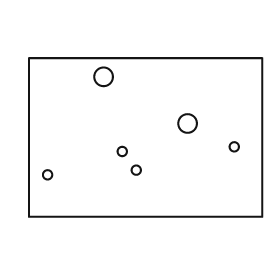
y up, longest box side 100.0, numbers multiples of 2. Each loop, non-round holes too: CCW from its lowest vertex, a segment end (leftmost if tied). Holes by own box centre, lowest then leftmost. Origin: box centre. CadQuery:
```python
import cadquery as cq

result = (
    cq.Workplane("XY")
    .moveTo(-50.0, -34.0)
    .lineTo(50.0, -34.0)
    .lineTo(50.0, 34.0)
    .lineTo(-50.0, 34.0)
    .close()
    .moveTo(-42.0, -16.0)
    .circle(2.0)
    .moveTo(-4.0, -14.0)
    .circle(2.0)
    .moveTo(-10.0, -6.0)
    .circle(2.0)
    .moveTo(38.0, -4.0)
    .circle(2.0)
    .moveTo(18.0, 6.0)
    .circle(4.0)
    .moveTo(-18.0, 26.0)
    .circle(4.0)
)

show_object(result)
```